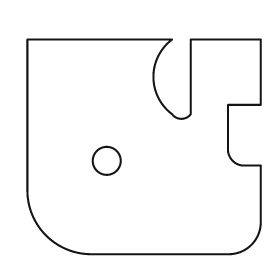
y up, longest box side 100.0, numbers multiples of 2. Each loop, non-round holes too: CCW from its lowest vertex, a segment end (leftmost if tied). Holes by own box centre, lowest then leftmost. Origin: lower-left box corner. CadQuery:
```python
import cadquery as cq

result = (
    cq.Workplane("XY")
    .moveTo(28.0, 0.0)
    .lineTo(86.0, 0.0)
    .threePointArc((96.0, 4.0), (100.0, 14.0))
    .lineTo(100.0, 38.0)
    .lineTo(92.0, 38.0)
    .threePointArc((88.0, 40.0), (86.0, 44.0))
    .lineTo(86.0, 64.0)
    .lineTo(100.0, 64.0)
    .lineTo(100.0, 92.0)
    .lineTo(70.0, 92.0)
    .lineTo(70.0, 60.0)
    .threePointArc((66.0, 58.0), (62.0, 60.0))
    .threePointArc((54.0, 76.0), (62.0, 92.0))
    .lineTo(0.0, 92.0)
    .lineTo(0.0, 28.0)
    .threePointArc((8.0, 8.0), (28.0, 0.0))
    .close()
    .moveTo(34.0, 40.0)
    .circle(6.0)
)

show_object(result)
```